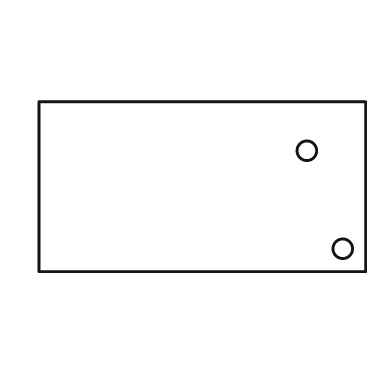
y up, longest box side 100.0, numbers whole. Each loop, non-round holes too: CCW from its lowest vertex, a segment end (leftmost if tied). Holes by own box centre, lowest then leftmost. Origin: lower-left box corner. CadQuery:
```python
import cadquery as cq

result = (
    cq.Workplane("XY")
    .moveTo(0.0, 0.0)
    .lineTo(100.0, 0.0)
    .lineTo(100.0, 52.0)
    .lineTo(0.0, 52.0)
    .close()
    .moveTo(93.0, 7.0)
    .circle(3.0)
    .moveTo(82.0, 37.0)
    .circle(3.0)
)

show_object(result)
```